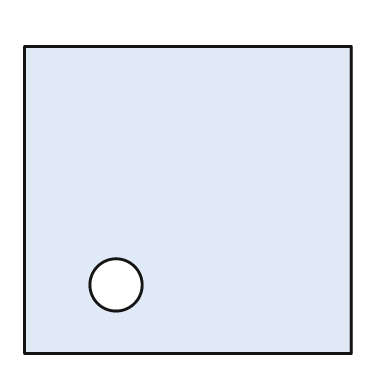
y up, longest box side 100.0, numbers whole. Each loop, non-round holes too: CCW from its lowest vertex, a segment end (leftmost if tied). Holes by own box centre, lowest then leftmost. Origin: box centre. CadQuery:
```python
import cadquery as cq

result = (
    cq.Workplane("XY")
    .moveTo(-50.0, -47.0)
    .lineTo(50.0, -47.0)
    .lineTo(50.0, 47.0)
    .lineTo(-50.0, 47.0)
    .close()
    .moveTo(-22.0, -26.0)
    .circle(8.0)
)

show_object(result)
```